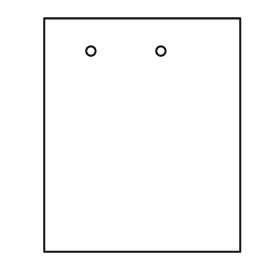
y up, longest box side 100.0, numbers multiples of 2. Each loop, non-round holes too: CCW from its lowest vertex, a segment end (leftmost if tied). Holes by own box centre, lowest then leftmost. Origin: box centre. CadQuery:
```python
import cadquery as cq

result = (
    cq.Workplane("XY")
    .moveTo(-42.0, -50.0)
    .lineTo(42.0, -50.0)
    .lineTo(42.0, 50.0)
    .lineTo(-42.0, 50.0)
    .close()
    .moveTo(-22.0, 36.0)
    .circle(2.0)
    .moveTo(8.0, 36.0)
    .circle(2.0)
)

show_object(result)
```